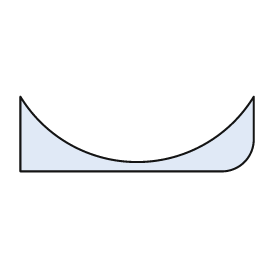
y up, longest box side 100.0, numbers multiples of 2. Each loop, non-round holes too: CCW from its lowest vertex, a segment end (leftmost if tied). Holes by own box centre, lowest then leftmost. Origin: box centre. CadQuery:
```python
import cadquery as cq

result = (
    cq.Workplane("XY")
    .moveTo(-50.0, -16.0)
    .lineTo(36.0, -16.0)
    .threePointArc((46.0, -12.0), (50.0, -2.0))
    .lineTo(50.0, 16.0)
    .threePointArc((0.0, -12.0), (-50.0, 16.0))
    .close()
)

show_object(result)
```